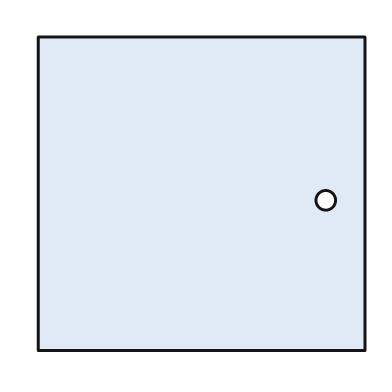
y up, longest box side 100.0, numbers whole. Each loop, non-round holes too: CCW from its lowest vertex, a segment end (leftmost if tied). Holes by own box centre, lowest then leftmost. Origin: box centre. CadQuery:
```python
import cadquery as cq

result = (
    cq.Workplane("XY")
    .moveTo(-50.0, -48.0)
    .lineTo(50.0, -48.0)
    .lineTo(50.0, 48.0)
    .lineTo(-50.0, 48.0)
    .close()
    .moveTo(38.0, -2.0)
    .circle(3.0)
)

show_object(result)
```